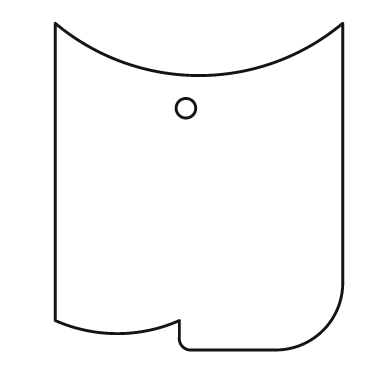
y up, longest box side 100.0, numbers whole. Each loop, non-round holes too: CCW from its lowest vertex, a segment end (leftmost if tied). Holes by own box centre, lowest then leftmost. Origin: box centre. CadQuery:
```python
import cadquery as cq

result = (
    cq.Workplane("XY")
    .moveTo(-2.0, -50.0)
    .lineTo(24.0, -50.0)
    .threePointArc((38.0, -44.0), (44.0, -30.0))
    .lineTo(44.0, 50.0)
    .threePointArc((0.0, 34.0), (-44.0, 50.0))
    .lineTo(-44.0, -41.0)
    .threePointArc((-25.0, -45.0), (-6.0, -41.0))
    .lineTo(-6.0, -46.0)
    .threePointArc((-5.0, -49.0), (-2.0, -50.0))
    .close()
    .moveTo(-4.0, 24.0)
    .circle(3.0)
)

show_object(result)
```